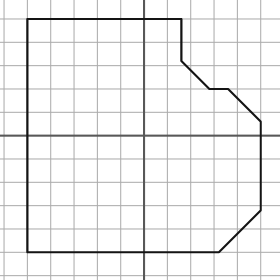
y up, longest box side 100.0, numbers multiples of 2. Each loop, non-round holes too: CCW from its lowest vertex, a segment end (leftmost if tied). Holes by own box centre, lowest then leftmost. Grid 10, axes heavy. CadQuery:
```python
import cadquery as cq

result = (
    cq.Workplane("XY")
    .moveTo(-50.0, -50.0)
    .lineTo(32.0, -50.0)
    .lineTo(50.0, -32.0)
    .lineTo(50.0, 6.0)
    .lineTo(36.0, 20.0)
    .lineTo(28.0, 20.0)
    .lineTo(16.0, 32.0)
    .lineTo(16.0, 50.0)
    .lineTo(-50.0, 50.0)
    .close()
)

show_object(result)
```